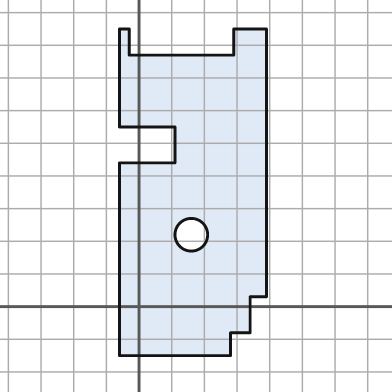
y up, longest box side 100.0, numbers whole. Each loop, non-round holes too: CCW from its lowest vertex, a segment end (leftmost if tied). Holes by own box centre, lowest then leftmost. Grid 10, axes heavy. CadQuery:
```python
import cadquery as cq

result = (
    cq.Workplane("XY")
    .moveTo(-6.0, -15.0)
    .lineTo(28.0, -15.0)
    .lineTo(28.0, -8.0)
    .lineTo(34.0, -8.0)
    .lineTo(34.0, 3.0)
    .lineTo(39.0, 3.0)
    .lineTo(39.0, 85.0)
    .lineTo(29.0, 85.0)
    .lineTo(29.0, 77.0)
    .lineTo(-3.0, 77.0)
    .lineTo(-3.0, 85.0)
    .lineTo(-6.0, 85.0)
    .lineTo(-6.0, 55.0)
    .lineTo(11.0, 55.0)
    .lineTo(11.0, 44.0)
    .lineTo(-6.0, 44.0)
    .close()
    .moveTo(16.0, 22.0)
    .circle(5.0)
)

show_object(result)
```